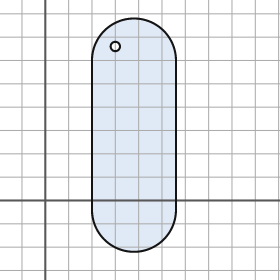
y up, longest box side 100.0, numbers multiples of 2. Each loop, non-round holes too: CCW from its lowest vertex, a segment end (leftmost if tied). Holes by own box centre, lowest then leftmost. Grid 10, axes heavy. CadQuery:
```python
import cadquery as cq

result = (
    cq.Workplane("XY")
    .moveTo(20.0, -4.0)
    .threePointArc((38.0, -22.0), (56.0, -4.0))
    .lineTo(56.0, 60.0)
    .threePointArc((38.0, 78.0), (20.0, 60.0))
    .close()
    .moveTo(30.0, 66.0)
    .circle(2.0)
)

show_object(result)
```